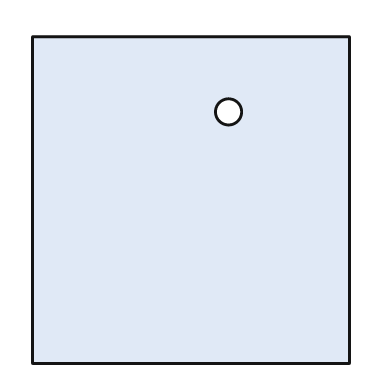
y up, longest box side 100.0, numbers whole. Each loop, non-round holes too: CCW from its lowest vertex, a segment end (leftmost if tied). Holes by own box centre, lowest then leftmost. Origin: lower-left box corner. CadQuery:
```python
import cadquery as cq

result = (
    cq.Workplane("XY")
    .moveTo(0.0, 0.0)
    .lineTo(97.0, 0.0)
    .lineTo(97.0, 100.0)
    .lineTo(0.0, 100.0)
    .close()
    .moveTo(60.0, 77.0)
    .circle(4.0)
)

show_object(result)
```